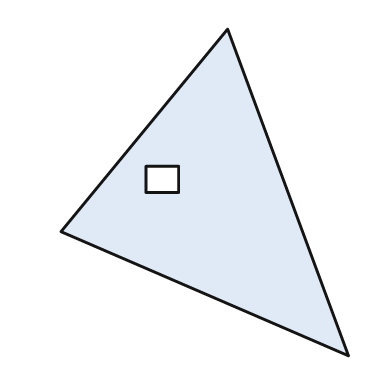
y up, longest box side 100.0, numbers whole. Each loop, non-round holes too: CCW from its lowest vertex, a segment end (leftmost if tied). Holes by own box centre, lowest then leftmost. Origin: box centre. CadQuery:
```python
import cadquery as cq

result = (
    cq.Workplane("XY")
    .moveTo(44.0, -50.0)
    .lineTo(7.0, 50.0)
    .lineTo(-44.0, -12.0)
    .close()
    .moveTo(-18.0, 0.0)
    .lineTo(-8.0, 0.0)
    .lineTo(-8.0, 8.0)
    .lineTo(-18.0, 8.0)
    .close()
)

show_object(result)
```